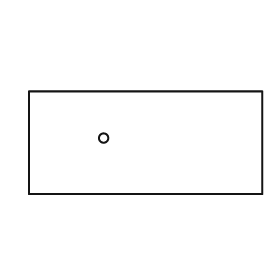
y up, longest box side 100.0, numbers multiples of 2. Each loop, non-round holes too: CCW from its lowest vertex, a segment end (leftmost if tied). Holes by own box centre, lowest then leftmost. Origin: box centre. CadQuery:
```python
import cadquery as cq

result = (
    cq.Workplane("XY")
    .moveTo(-50.0, -22.0)
    .lineTo(50.0, -22.0)
    .lineTo(50.0, 22.0)
    .lineTo(-50.0, 22.0)
    .close()
    .moveTo(-18.0, 2.0)
    .circle(2.0)
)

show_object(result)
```